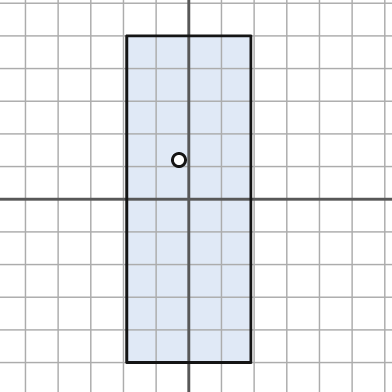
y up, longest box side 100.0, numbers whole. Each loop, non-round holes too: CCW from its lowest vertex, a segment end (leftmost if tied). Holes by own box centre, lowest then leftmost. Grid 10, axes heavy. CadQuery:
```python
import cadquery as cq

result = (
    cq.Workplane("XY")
    .moveTo(-19.0, -50.0)
    .lineTo(19.0, -50.0)
    .lineTo(19.0, 50.0)
    .lineTo(-19.0, 50.0)
    .close()
    .moveTo(-3.0, 12.0)
    .circle(2.0)
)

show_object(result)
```